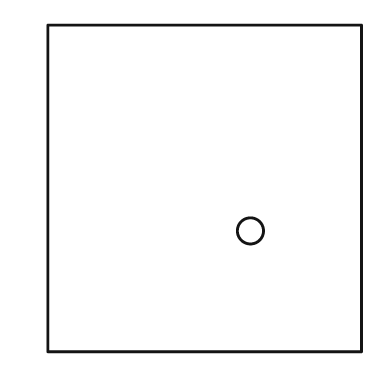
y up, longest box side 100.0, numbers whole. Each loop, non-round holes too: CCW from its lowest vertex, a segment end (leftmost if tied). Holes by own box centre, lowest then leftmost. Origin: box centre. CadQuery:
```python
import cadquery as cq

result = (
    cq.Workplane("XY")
    .moveTo(-48.0, -50.0)
    .lineTo(48.0, -50.0)
    .lineTo(48.0, 50.0)
    .lineTo(-48.0, 50.0)
    .close()
    .moveTo(14.0, -13.0)
    .circle(4.0)
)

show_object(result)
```